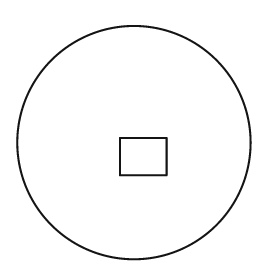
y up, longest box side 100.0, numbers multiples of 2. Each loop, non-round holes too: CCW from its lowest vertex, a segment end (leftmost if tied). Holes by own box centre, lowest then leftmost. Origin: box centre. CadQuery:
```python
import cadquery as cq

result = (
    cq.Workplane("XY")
    .moveTo(0.0, 0.0)
    .circle(50.0)
    .moveTo(-6.0, -14.0)
    .lineTo(14.0, -14.0)
    .lineTo(14.0, 2.0)
    .lineTo(-6.0, 2.0)
    .close()
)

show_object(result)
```